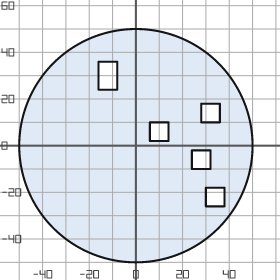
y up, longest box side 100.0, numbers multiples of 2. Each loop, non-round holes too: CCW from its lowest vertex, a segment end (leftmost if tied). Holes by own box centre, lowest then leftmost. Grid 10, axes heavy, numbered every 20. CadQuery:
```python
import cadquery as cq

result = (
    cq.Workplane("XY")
    .moveTo(0.0, 0.0)
    .circle(50.0)
    .moveTo(30.0, -26.0)
    .lineTo(38.0, -26.0)
    .lineTo(38.0, -18.0)
    .lineTo(30.0, -18.0)
    .close()
    .moveTo(24.0, -10.0)
    .lineTo(32.0, -10.0)
    .lineTo(32.0, -2.0)
    .lineTo(24.0, -2.0)
    .close()
    .moveTo(6.0, 2.0)
    .lineTo(14.0, 2.0)
    .lineTo(14.0, 10.0)
    .lineTo(6.0, 10.0)
    .close()
    .moveTo(28.0, 10.0)
    .lineTo(36.0, 10.0)
    .lineTo(36.0, 18.0)
    .lineTo(28.0, 18.0)
    .close()
    .moveTo(-16.0, 24.0)
    .lineTo(-8.0, 24.0)
    .lineTo(-8.0, 36.0)
    .lineTo(-16.0, 36.0)
    .close()
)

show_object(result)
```